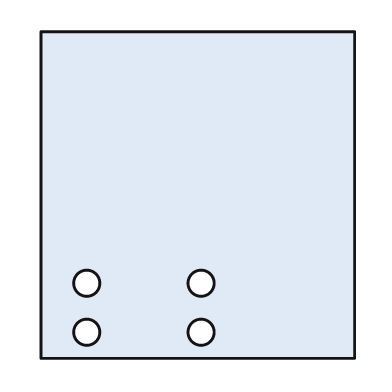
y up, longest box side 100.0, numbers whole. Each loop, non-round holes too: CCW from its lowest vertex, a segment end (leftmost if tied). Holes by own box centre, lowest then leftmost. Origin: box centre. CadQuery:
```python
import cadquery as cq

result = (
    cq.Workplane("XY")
    .moveTo(-48.0, -50.0)
    .lineTo(48.0, -50.0)
    .lineTo(48.0, 50.0)
    .lineTo(-48.0, 50.0)
    .close()
    .moveTo(-34.0, -42.0)
    .circle(4.0)
    .moveTo(1.0, -42.0)
    .circle(4.0)
    .moveTo(-34.0, -27.0)
    .circle(4.0)
    .moveTo(1.0, -27.0)
    .circle(4.0)
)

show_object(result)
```